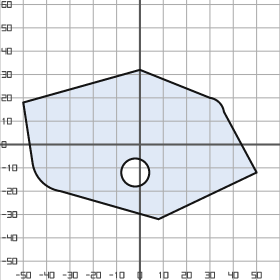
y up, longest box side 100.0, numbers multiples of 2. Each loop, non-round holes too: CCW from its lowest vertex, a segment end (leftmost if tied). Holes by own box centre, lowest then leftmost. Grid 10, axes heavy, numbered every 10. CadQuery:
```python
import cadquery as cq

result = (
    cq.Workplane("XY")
    .moveTo(8.0, -32.0)
    .lineTo(50.0, -12.0)
    .lineTo(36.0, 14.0)
    .threePointArc((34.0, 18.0), (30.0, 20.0))
    .lineTo(0.0, 32.0)
    .lineTo(-50.0, 18.0)
    .lineTo(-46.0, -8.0)
    .threePointArc((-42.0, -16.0), (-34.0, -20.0))
    .close()
    .moveTo(-2.0, -12.0)
    .circle(6.0)
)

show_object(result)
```